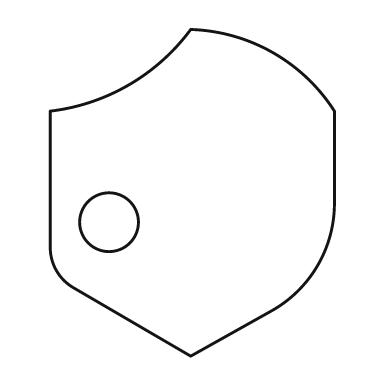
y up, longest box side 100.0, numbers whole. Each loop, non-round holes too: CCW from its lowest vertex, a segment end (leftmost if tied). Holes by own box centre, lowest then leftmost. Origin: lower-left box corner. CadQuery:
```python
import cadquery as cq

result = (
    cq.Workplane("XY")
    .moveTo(43.0, 0.0)
    .lineTo(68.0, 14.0)
    .threePointArc((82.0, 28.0), (87.0, 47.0))
    .lineTo(87.0, 75.0)
    .threePointArc((68.0, 93.0), (43.0, 100.0))
    .threePointArc((24.0, 83.0), (0.0, 75.0))
    .lineTo(0.0, 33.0)
    .threePointArc((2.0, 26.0), (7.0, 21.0))
    .close()
    .moveTo(18.0, 41.0)
    .circle(9.0)
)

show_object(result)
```